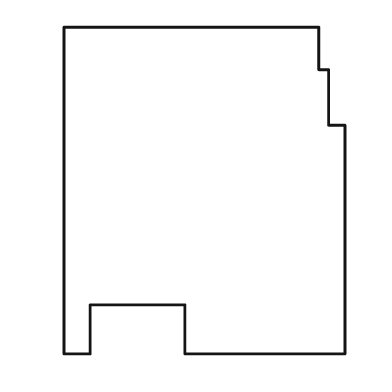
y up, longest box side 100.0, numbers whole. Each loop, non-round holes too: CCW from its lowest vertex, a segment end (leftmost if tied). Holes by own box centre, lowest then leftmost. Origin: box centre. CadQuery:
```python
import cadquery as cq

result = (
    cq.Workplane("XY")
    .moveTo(-43.0, -50.0)
    .lineTo(-35.0, -50.0)
    .lineTo(-35.0, -35.0)
    .lineTo(-6.0, -35.0)
    .lineTo(-6.0, -50.0)
    .lineTo(43.0, -50.0)
    .lineTo(43.0, 20.0)
    .lineTo(38.0, 20.0)
    .lineTo(38.0, 37.0)
    .lineTo(35.0, 37.0)
    .lineTo(35.0, 50.0)
    .lineTo(-43.0, 50.0)
    .close()
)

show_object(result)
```